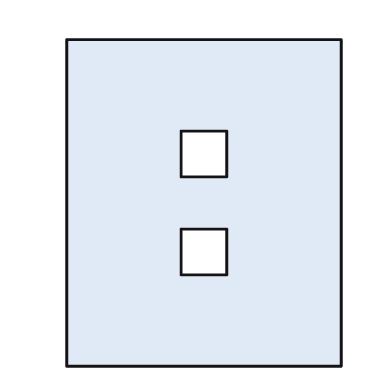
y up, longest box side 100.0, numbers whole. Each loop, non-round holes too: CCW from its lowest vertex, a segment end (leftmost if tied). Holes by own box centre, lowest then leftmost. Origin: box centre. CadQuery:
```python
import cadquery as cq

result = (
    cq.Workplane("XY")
    .moveTo(-42.0, -50.0)
    .lineTo(42.0, -50.0)
    .lineTo(42.0, 50.0)
    .lineTo(-42.0, 50.0)
    .close()
    .moveTo(-7.0, -22.0)
    .lineTo(7.0, -22.0)
    .lineTo(7.0, -8.0)
    .lineTo(-7.0, -8.0)
    .close()
    .moveTo(-7.0, 8.0)
    .lineTo(7.0, 8.0)
    .lineTo(7.0, 22.0)
    .lineTo(-7.0, 22.0)
    .close()
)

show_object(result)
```